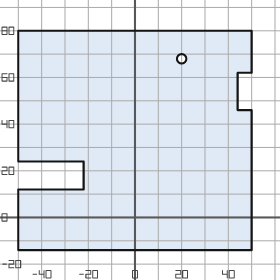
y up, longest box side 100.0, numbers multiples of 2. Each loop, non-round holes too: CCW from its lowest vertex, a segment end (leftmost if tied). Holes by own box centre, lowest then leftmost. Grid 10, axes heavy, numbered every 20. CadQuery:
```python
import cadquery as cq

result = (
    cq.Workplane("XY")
    .moveTo(-50.0, -14.0)
    .lineTo(50.0, -14.0)
    .lineTo(50.0, 46.0)
    .lineTo(44.0, 46.0)
    .lineTo(44.0, 62.0)
    .lineTo(50.0, 62.0)
    .lineTo(50.0, 80.0)
    .lineTo(-50.0, 80.0)
    .lineTo(-50.0, 24.0)
    .lineTo(-22.0, 24.0)
    .lineTo(-22.0, 12.0)
    .lineTo(-50.0, 12.0)
    .close()
    .moveTo(20.0, 68.0)
    .circle(2.0)
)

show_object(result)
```